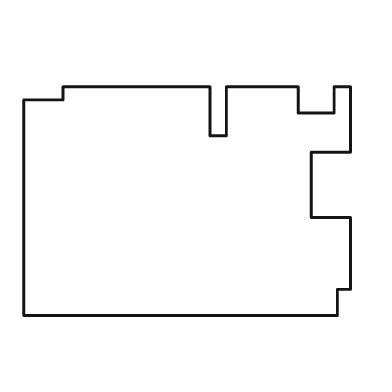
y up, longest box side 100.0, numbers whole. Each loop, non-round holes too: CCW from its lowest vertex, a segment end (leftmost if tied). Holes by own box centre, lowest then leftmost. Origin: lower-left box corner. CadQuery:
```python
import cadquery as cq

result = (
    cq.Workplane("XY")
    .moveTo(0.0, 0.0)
    .lineTo(96.0, 0.0)
    .lineTo(96.0, 8.0)
    .lineTo(100.0, 8.0)
    .lineTo(100.0, 30.0)
    .lineTo(88.0, 30.0)
    .lineTo(88.0, 50.0)
    .lineTo(100.0, 50.0)
    .lineTo(100.0, 70.0)
    .lineTo(95.0, 70.0)
    .lineTo(95.0, 62.0)
    .lineTo(84.0, 62.0)
    .lineTo(84.0, 70.0)
    .lineTo(62.0, 70.0)
    .lineTo(62.0, 55.0)
    .lineTo(57.0, 55.0)
    .lineTo(57.0, 70.0)
    .lineTo(12.0, 70.0)
    .lineTo(12.0, 66.0)
    .lineTo(0.0, 66.0)
    .close()
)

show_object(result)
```